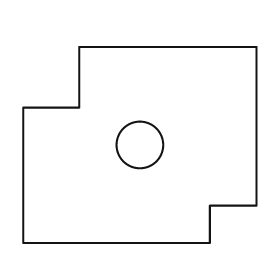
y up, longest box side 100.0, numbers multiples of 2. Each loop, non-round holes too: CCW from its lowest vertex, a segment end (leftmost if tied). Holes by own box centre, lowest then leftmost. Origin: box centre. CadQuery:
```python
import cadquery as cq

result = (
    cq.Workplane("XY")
    .moveTo(-50.0, -42.0)
    .lineTo(30.0, -42.0)
    .lineTo(30.0, -26.0)
    .lineTo(50.0, -26.0)
    .lineTo(50.0, 42.0)
    .lineTo(-26.0, 42.0)
    .lineTo(-26.0, 16.0)
    .lineTo(-50.0, 16.0)
    .close()
    .moveTo(0.0, 0.0)
    .circle(10.0)
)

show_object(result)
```